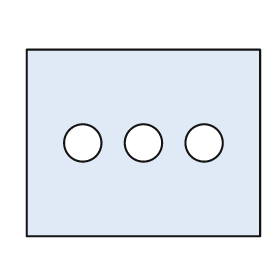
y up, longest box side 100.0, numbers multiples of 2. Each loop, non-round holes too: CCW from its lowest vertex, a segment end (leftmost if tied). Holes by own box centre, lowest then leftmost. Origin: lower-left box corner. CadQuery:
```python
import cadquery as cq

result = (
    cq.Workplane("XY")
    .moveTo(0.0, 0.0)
    .lineTo(100.0, 0.0)
    .lineTo(100.0, 80.0)
    .lineTo(0.0, 80.0)
    .close()
    .moveTo(24.0, 40.0)
    .circle(8.0)
    .moveTo(50.0, 40.0)
    .circle(8.0)
    .moveTo(76.0, 40.0)
    .circle(8.0)
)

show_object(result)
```